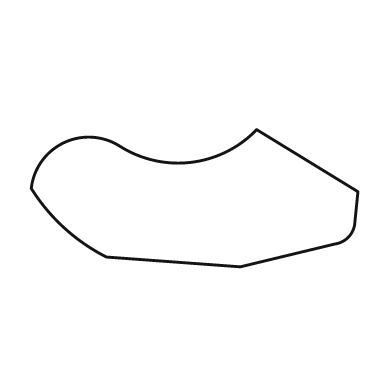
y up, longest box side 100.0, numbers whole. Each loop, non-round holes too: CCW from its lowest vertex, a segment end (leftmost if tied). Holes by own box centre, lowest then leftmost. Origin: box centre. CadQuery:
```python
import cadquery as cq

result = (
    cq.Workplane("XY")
    .moveTo(14.0, -21.0)
    .lineTo(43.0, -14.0)
    .threePointArc((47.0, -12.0), (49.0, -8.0))
    .lineTo(50.0, 2.0)
    .lineTo(19.0, 21.0)
    .threePointArc((-1.0, 11.0), (-23.0, 16.0))
    .threePointArc((-40.0, 17.0), (-50.0, 3.0))
    .threePointArc((-40.0, -9.0), (-27.0, -18.0))
    .close()
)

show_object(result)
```